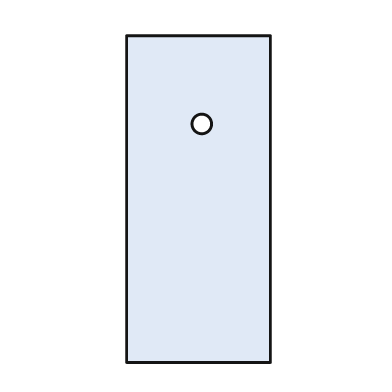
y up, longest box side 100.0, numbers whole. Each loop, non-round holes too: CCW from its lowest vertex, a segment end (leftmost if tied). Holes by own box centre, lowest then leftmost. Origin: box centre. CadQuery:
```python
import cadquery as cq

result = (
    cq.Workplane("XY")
    .moveTo(-22.0, -50.0)
    .lineTo(22.0, -50.0)
    .lineTo(22.0, 50.0)
    .lineTo(-22.0, 50.0)
    .close()
    .moveTo(1.0, 23.0)
    .circle(3.0)
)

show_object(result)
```